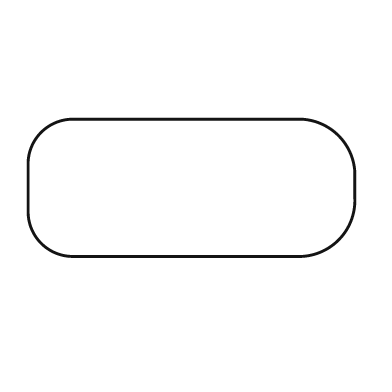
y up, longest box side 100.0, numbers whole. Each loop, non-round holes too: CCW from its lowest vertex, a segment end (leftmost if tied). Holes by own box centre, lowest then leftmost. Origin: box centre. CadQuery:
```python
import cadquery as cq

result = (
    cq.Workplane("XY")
    .moveTo(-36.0, -21.0)
    .lineTo(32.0, -21.0)
    .threePointArc((45.0, -16.0), (50.0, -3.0))
    .lineTo(50.0, 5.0)
    .threePointArc((45.0, 16.0), (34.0, 21.0))
    .lineTo(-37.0, 21.0)
    .threePointArc((-46.0, 17.0), (-50.0, 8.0))
    .lineTo(-50.0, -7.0)
    .threePointArc((-46.0, -17.0), (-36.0, -21.0))
    .close()
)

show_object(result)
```